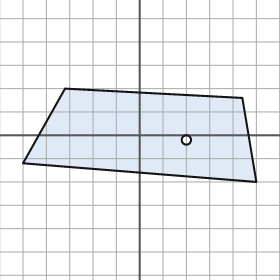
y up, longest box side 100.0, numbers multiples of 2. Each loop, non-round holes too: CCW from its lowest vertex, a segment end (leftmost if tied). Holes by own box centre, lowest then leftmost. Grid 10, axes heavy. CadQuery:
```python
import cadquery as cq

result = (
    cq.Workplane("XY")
    .moveTo(50.0, -20.0)
    .lineTo(44.0, 16.0)
    .lineTo(-32.0, 20.0)
    .lineTo(-50.0, -12.0)
    .close()
    .moveTo(20.0, -2.0)
    .circle(2.0)
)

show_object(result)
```